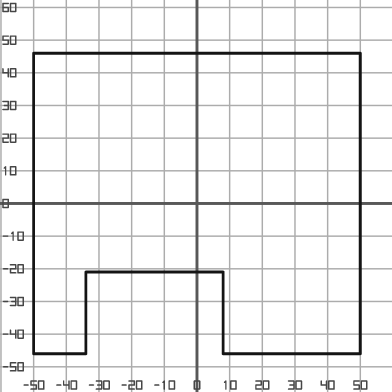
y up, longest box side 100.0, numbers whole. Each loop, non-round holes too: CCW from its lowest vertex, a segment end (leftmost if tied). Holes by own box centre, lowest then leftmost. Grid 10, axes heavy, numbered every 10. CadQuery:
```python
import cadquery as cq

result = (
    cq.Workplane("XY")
    .moveTo(-50.0, -46.0)
    .lineTo(-34.0, -46.0)
    .lineTo(-34.0, -21.0)
    .lineTo(8.0, -21.0)
    .lineTo(8.0, -46.0)
    .lineTo(50.0, -46.0)
    .lineTo(50.0, 46.0)
    .lineTo(-50.0, 46.0)
    .close()
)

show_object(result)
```